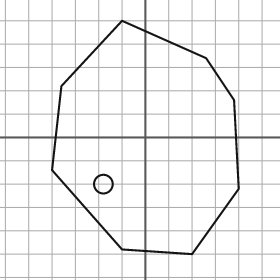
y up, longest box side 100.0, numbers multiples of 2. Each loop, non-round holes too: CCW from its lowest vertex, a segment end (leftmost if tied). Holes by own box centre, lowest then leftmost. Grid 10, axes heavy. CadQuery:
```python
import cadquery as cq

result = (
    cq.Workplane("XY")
    .moveTo(20.0, -50.0)
    .lineTo(40.0, -22.0)
    .lineTo(38.0, 16.0)
    .lineTo(26.0, 34.0)
    .lineTo(-10.0, 50.0)
    .lineTo(-36.0, 22.0)
    .lineTo(-40.0, -14.0)
    .lineTo(-10.0, -48.0)
    .close()
    .moveTo(-18.0, -20.0)
    .circle(4.0)
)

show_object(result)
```